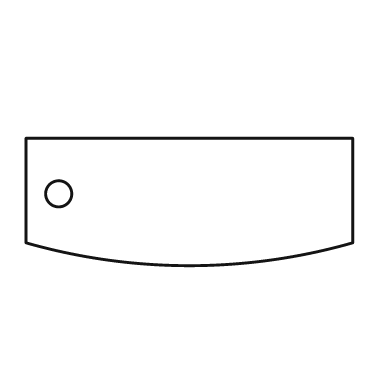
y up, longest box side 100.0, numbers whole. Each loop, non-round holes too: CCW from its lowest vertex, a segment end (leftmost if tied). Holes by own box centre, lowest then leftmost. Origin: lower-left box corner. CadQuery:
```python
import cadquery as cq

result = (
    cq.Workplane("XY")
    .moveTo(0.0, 7.0)
    .threePointArc((50.0, 0.0), (100.0, 7.0))
    .lineTo(100.0, 39.0)
    .lineTo(0.0, 39.0)
    .close()
    .moveTo(10.0, 22.0)
    .circle(4.0)
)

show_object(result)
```